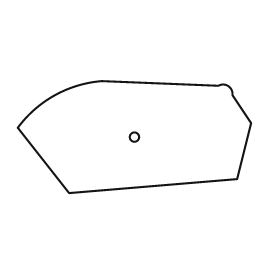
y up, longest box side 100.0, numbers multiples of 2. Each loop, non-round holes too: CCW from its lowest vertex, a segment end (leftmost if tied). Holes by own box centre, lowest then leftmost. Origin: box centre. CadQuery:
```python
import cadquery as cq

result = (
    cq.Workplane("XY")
    .moveTo(-28.0, -24.0)
    .lineTo(44.0, -18.0)
    .lineTo(50.0, 6.0)
    .lineTo(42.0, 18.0)
    .threePointArc((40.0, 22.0), (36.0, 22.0))
    .lineTo(-14.0, 24.0)
    .threePointArc((-34.0, 18.0), (-50.0, 4.0))
    .close()
    .moveTo(0.0, 0.0)
    .circle(2.0)
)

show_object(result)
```